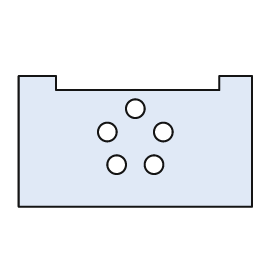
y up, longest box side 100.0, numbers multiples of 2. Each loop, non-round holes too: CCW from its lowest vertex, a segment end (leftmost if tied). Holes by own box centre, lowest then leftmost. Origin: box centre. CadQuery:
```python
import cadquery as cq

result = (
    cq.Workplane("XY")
    .moveTo(-50.0, -28.0)
    .lineTo(50.0, -28.0)
    .lineTo(50.0, 28.0)
    .lineTo(36.0, 28.0)
    .lineTo(36.0, 22.0)
    .lineTo(-34.0, 22.0)
    .lineTo(-34.0, 28.0)
    .lineTo(-50.0, 28.0)
    .close()
    .moveTo(-8.0, -10.0)
    .circle(4.0)
    .moveTo(8.0, -10.0)
    .circle(4.0)
    .moveTo(-12.0, 4.0)
    .circle(4.0)
    .moveTo(12.0, 4.0)
    .circle(4.0)
    .moveTo(0.0, 14.0)
    .circle(4.0)
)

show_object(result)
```